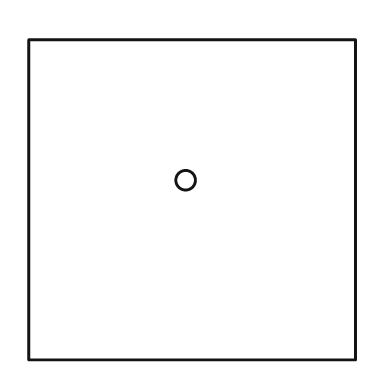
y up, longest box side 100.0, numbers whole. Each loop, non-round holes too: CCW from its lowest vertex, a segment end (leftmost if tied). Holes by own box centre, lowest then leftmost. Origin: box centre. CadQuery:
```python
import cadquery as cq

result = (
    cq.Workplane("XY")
    .moveTo(-50.0, -49.0)
    .lineTo(50.0, -49.0)
    .lineTo(50.0, 49.0)
    .lineTo(-50.0, 49.0)
    .close()
    .moveTo(-2.0, 6.0)
    .circle(3.0)
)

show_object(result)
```